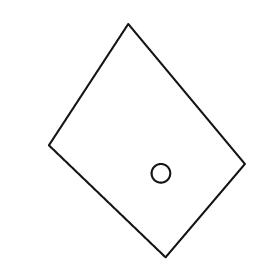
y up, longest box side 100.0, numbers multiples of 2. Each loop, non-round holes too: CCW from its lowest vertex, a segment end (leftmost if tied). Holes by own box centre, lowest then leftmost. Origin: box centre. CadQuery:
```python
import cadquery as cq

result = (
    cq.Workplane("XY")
    .moveTo(8.0, -50.0)
    .lineTo(42.0, -10.0)
    .lineTo(-8.0, 50.0)
    .lineTo(-42.0, -2.0)
    .close()
    .moveTo(6.0, -14.0)
    .circle(4.0)
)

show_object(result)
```